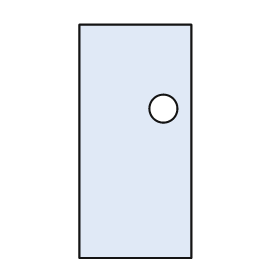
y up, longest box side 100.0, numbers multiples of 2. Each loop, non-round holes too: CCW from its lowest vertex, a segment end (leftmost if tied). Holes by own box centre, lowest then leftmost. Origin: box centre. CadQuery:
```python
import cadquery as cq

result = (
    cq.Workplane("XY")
    .moveTo(-24.0, -50.0)
    .lineTo(24.0, -50.0)
    .lineTo(24.0, 50.0)
    .lineTo(-24.0, 50.0)
    .close()
    .moveTo(12.0, 14.0)
    .circle(6.0)
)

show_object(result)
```